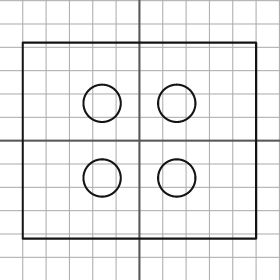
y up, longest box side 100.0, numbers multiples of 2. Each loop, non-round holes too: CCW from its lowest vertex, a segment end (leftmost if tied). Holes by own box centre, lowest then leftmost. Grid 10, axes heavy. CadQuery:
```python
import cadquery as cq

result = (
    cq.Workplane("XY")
    .moveTo(-50.0, -42.0)
    .lineTo(50.0, -42.0)
    .lineTo(50.0, 42.0)
    .lineTo(-50.0, 42.0)
    .close()
    .moveTo(-16.0, -16.0)
    .circle(8.0)
    .moveTo(16.0, -16.0)
    .circle(8.0)
    .moveTo(-16.0, 16.0)
    .circle(8.0)
    .moveTo(16.0, 16.0)
    .circle(8.0)
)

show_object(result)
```